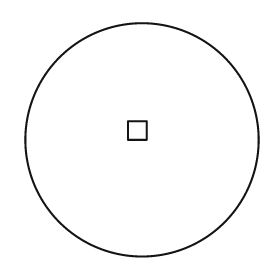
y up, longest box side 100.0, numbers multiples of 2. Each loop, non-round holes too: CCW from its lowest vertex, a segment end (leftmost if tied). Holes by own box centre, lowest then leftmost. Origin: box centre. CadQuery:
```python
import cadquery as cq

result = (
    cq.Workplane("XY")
    .moveTo(0.0, 0.0)
    .circle(50.0)
    .moveTo(-6.0, 0.0)
    .lineTo(2.0, 0.0)
    .lineTo(2.0, 8.0)
    .lineTo(-6.0, 8.0)
    .close()
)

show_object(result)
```